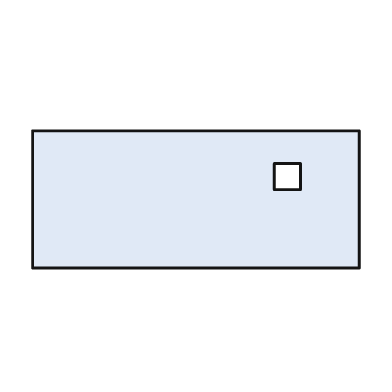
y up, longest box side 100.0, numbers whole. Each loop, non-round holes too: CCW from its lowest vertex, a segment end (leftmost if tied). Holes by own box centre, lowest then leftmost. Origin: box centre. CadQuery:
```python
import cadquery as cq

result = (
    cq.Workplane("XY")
    .moveTo(-50.0, -21.0)
    .lineTo(50.0, -21.0)
    .lineTo(50.0, 21.0)
    .lineTo(-50.0, 21.0)
    .close()
    .moveTo(24.0, 3.0)
    .lineTo(32.0, 3.0)
    .lineTo(32.0, 11.0)
    .lineTo(24.0, 11.0)
    .close()
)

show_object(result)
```